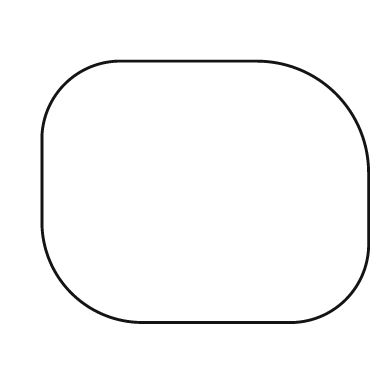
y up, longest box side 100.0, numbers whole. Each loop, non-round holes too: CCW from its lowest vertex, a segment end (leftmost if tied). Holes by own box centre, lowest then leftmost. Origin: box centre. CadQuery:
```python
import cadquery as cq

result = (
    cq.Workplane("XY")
    .moveTo(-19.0, -40.0)
    .lineTo(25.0, -40.0)
    .threePointArc((43.0, -33.0), (50.0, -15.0))
    .lineTo(50.0, 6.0)
    .threePointArc((40.0, 30.0), (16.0, 40.0))
    .lineTo(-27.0, 40.0)
    .threePointArc((-43.0, 33.0), (-50.0, 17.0))
    .lineTo(-50.0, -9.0)
    .threePointArc((-41.0, -31.0), (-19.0, -40.0))
    .close()
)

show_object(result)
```